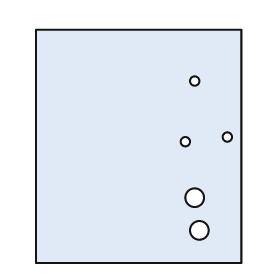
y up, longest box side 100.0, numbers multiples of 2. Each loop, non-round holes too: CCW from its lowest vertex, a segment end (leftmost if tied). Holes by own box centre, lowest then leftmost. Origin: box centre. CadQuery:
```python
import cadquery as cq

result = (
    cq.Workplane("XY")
    .moveTo(-44.0, -50.0)
    .lineTo(44.0, -50.0)
    .lineTo(44.0, 50.0)
    .lineTo(-44.0, 50.0)
    .close()
    .moveTo(26.0, -36.0)
    .circle(4.0)
    .moveTo(24.0, -22.0)
    .circle(4.0)
    .moveTo(20.0, 2.0)
    .circle(2.0)
    .moveTo(38.0, 4.0)
    .circle(2.0)
    .moveTo(24.0, 28.0)
    .circle(2.0)
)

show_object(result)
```